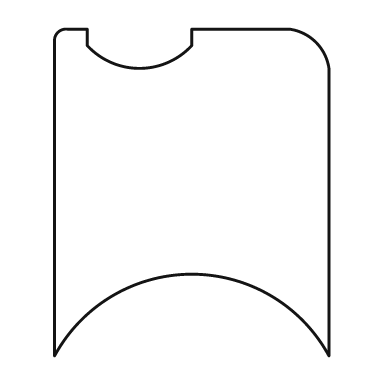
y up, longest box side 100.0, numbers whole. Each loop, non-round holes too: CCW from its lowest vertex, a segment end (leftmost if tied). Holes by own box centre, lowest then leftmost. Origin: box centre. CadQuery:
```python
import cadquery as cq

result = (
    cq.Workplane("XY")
    .moveTo(-42.0, -50.0)
    .threePointArc((0.0, -25.0), (42.0, -50.0))
    .lineTo(42.0, 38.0)
    .threePointArc((38.0, 46.0), (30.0, 50.0))
    .lineTo(0.0, 50.0)
    .lineTo(0.0, 45.0)
    .threePointArc((-16.0, 38.0), (-32.0, 45.0))
    .lineTo(-32.0, 50.0)
    .lineTo(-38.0, 50.0)
    .threePointArc((-41.0, 49.0), (-42.0, 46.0))
    .close()
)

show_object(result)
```